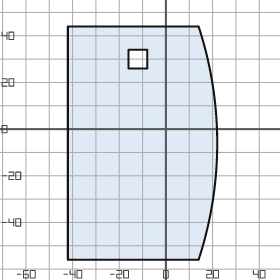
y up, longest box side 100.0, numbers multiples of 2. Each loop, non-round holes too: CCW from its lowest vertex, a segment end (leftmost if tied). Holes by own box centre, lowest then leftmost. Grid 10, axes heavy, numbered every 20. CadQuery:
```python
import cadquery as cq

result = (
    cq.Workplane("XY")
    .moveTo(-42.0, -56.0)
    .lineTo(14.0, -56.0)
    .threePointArc((22.0, -6.0), (14.0, 44.0))
    .lineTo(-42.0, 44.0)
    .close()
    .moveTo(-16.0, 26.0)
    .lineTo(-8.0, 26.0)
    .lineTo(-8.0, 34.0)
    .lineTo(-16.0, 34.0)
    .close()
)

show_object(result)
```